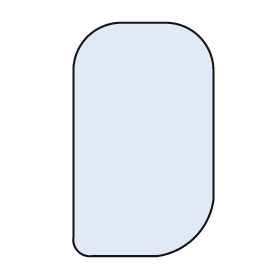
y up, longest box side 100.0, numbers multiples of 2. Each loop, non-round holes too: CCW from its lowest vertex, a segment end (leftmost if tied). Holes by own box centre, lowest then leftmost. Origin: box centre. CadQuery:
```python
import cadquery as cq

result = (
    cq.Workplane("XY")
    .moveTo(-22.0, -50.0)
    .lineTo(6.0, -50.0)
    .threePointArc((22.0, -42.0), (30.0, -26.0))
    .lineTo(30.0, 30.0)
    .threePointArc((24.0, 44.0), (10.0, 50.0))
    .lineTo(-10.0, 50.0)
    .threePointArc((-24.0, 44.0), (-30.0, 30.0))
    .lineTo(-30.0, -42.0)
    .threePointArc((-28.0, -48.0), (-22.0, -50.0))
    .close()
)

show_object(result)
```